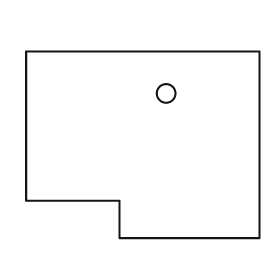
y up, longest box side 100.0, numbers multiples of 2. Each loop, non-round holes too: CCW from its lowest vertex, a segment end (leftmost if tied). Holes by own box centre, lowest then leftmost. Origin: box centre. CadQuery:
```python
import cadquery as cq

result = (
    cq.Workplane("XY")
    .moveTo(-10.0, -40.0)
    .lineTo(50.0, -40.0)
    .lineTo(50.0, 40.0)
    .lineTo(-50.0, 40.0)
    .lineTo(-50.0, -24.0)
    .lineTo(-10.0, -24.0)
    .close()
    .moveTo(10.0, 22.0)
    .circle(4.0)
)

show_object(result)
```